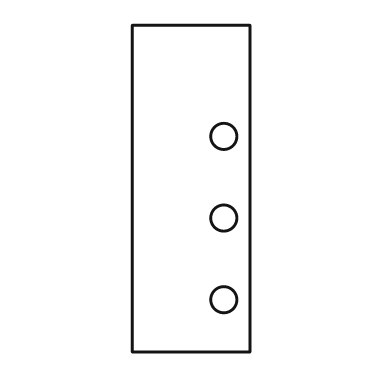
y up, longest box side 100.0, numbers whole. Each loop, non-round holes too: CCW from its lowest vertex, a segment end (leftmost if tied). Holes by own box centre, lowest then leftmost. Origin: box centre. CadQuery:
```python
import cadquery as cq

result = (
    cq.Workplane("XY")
    .moveTo(-18.0, -50.0)
    .lineTo(18.0, -50.0)
    .lineTo(18.0, 50.0)
    .lineTo(-18.0, 50.0)
    .close()
    .moveTo(10.0, -34.0)
    .circle(4.0)
    .moveTo(10.0, -9.0)
    .circle(4.0)
    .moveTo(10.0, 16.0)
    .circle(4.0)
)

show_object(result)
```